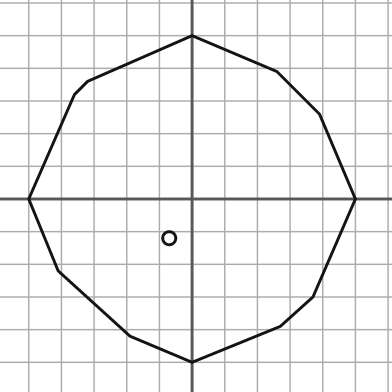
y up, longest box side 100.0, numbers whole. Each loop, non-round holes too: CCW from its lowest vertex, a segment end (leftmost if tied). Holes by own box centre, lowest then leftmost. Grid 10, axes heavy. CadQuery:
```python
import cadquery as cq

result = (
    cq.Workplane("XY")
    .moveTo(0.0, -50.0)
    .lineTo(27.0, -39.0)
    .lineTo(37.0, -30.0)
    .lineTo(50.0, 0.0)
    .lineTo(39.0, 26.0)
    .lineTo(26.0, 39.0)
    .lineTo(0.0, 50.0)
    .lineTo(-32.0, 36.0)
    .lineTo(-36.0, 32.0)
    .lineTo(-50.0, 0.0)
    .lineTo(-41.0, -22.0)
    .lineTo(-19.0, -42.0)
    .close()
    .moveTo(-7.0, -12.0)
    .circle(2.0)
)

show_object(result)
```